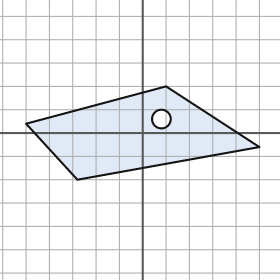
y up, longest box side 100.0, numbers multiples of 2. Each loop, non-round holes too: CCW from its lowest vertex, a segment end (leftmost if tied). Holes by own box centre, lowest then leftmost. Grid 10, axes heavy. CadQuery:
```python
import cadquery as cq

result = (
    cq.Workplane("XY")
    .moveTo(-28.0, -20.0)
    .lineTo(50.0, -6.0)
    .lineTo(10.0, 20.0)
    .lineTo(-50.0, 4.0)
    .close()
    .moveTo(8.0, 6.0)
    .circle(4.0)
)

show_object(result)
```